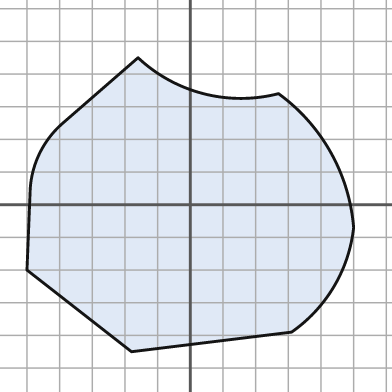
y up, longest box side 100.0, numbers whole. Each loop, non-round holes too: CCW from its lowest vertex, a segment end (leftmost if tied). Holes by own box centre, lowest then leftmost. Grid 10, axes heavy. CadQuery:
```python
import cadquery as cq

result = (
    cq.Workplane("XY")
    .moveTo(-18.0, -45.0)
    .lineTo(31.0, -39.0)
    .threePointArc((44.0, -25.0), (50.0, -7.0))
    .threePointArc((43.0, 16.0), (27.0, 34.0))
    .threePointArc((4.0, 34.0), (-16.0, 45.0))
    .lineTo(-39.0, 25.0)
    .threePointArc((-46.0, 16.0), (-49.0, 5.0))
    .lineTo(-50.0, -20.0)
    .close()
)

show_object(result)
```